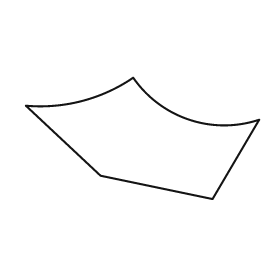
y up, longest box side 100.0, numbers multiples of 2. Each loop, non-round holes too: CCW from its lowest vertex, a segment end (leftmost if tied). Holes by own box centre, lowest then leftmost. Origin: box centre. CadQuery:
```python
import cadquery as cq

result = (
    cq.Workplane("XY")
    .moveTo(30.0, -26.0)
    .lineTo(50.0, 8.0)
    .threePointArc((20.0, 8.0), (-4.0, 26.0))
    .threePointArc((-26.0, 16.0), (-50.0, 14.0))
    .lineTo(-18.0, -16.0)
    .close()
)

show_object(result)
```